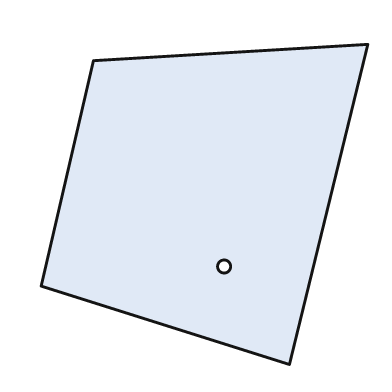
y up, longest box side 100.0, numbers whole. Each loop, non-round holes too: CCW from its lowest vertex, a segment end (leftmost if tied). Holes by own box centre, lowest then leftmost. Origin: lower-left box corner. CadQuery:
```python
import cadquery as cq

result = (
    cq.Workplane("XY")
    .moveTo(76.0, 0.0)
    .lineTo(100.0, 98.0)
    .lineTo(16.0, 93.0)
    .lineTo(0.0, 24.0)
    .close()
    .moveTo(56.0, 30.0)
    .circle(2.0)
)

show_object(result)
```